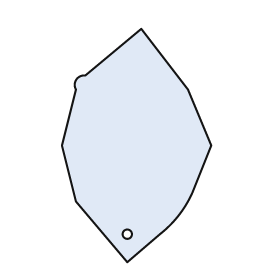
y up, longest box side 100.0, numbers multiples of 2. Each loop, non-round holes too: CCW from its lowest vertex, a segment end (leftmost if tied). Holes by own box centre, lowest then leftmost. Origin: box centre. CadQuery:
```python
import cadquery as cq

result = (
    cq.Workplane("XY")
    .moveTo(-4.0, -50.0)
    .lineTo(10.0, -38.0)
    .threePointArc((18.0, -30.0), (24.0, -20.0))
    .lineTo(32.0, 0.0)
    .lineTo(22.0, 24.0)
    .lineTo(2.0, 50.0)
    .lineTo(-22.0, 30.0)
    .threePointArc((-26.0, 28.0), (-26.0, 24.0))
    .lineTo(-32.0, 0.0)
    .lineTo(-26.0, -24.0)
    .close()
    .moveTo(-4.0, -38.0)
    .circle(2.0)
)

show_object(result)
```